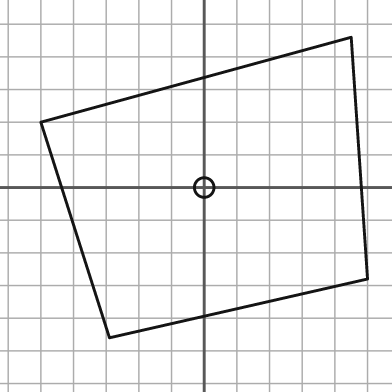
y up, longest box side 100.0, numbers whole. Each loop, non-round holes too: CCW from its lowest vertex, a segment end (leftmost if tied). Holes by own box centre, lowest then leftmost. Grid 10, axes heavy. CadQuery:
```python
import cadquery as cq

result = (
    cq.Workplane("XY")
    .moveTo(-29.0, -46.0)
    .lineTo(50.0, -28.0)
    .lineTo(45.0, 46.0)
    .lineTo(-50.0, 20.0)
    .close()
    .moveTo(0.0, 0.0)
    .circle(3.0)
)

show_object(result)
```